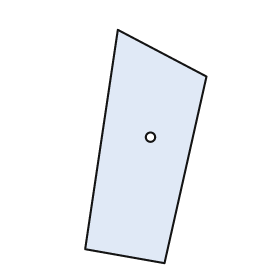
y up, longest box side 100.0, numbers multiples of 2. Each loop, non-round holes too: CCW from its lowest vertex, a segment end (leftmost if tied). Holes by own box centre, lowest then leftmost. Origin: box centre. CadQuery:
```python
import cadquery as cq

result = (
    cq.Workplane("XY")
    .moveTo(8.0, -50.0)
    .lineTo(26.0, 30.0)
    .lineTo(-12.0, 50.0)
    .lineTo(-26.0, -44.0)
    .close()
    .moveTo(2.0, 4.0)
    .circle(2.0)
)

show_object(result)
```